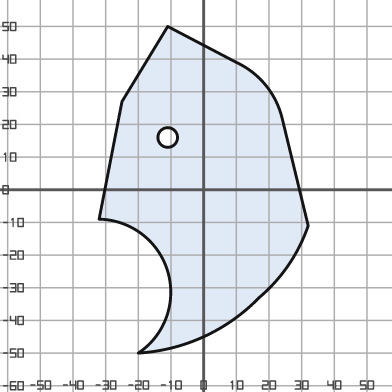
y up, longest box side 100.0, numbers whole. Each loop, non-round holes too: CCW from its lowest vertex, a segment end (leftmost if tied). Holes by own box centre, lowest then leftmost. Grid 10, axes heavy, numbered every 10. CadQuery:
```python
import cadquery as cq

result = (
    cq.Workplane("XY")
    .moveTo(-20.0, -50.0)
    .threePointArc((0.0, -45.0), (17.0, -33.0))
    .threePointArc((26.0, -23.0), (32.0, -11.0))
    .lineTo(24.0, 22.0)
    .threePointArc((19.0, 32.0), (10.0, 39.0))
    .lineTo(-11.0, 50.0)
    .lineTo(-25.0, 27.0)
    .lineTo(-32.0, -9.0)
    .threePointArc((-11.0, -25.0), (-20.0, -50.0))
    .close()
    .moveTo(-11.0, 16.0)
    .circle(3.0)
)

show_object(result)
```